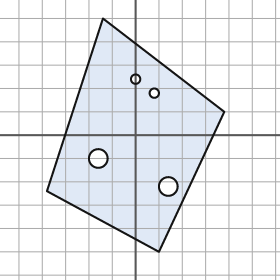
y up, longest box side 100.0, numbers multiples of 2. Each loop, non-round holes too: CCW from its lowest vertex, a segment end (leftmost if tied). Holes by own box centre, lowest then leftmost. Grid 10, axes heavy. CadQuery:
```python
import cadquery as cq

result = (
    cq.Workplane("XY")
    .moveTo(10.0, -50.0)
    .lineTo(38.0, 10.0)
    .lineTo(-14.0, 50.0)
    .lineTo(-38.0, -24.0)
    .close()
    .moveTo(14.0, -22.0)
    .circle(4.0)
    .moveTo(-16.0, -10.0)
    .circle(4.0)
    .moveTo(8.0, 18.0)
    .circle(2.0)
    .moveTo(0.0, 24.0)
    .circle(2.0)
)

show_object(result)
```